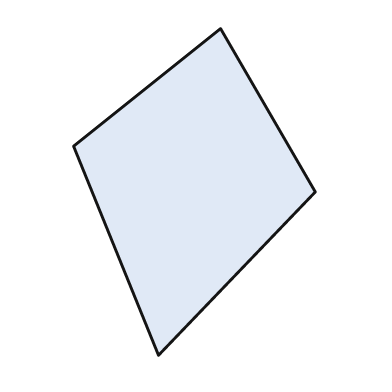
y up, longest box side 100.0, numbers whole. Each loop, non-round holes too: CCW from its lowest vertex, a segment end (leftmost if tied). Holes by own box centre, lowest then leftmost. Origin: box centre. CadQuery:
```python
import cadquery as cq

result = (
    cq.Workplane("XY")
    .moveTo(-11.0, -50.0)
    .lineTo(37.0, 0.0)
    .lineTo(8.0, 50.0)
    .lineTo(-37.0, 14.0)
    .close()
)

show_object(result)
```